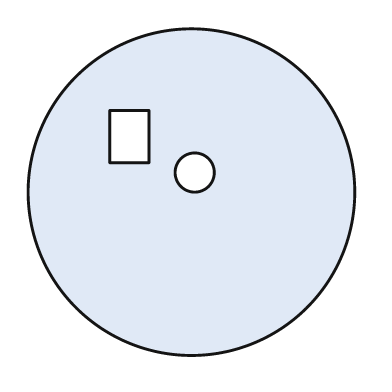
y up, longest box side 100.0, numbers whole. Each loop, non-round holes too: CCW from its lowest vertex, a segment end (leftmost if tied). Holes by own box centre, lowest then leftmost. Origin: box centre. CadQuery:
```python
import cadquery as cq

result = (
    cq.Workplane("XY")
    .moveTo(0.0, 0.0)
    .circle(50.0)
    .moveTo(1.0, 6.0)
    .circle(6.0)
    .moveTo(-25.0, 9.0)
    .lineTo(-13.0, 9.0)
    .lineTo(-13.0, 25.0)
    .lineTo(-25.0, 25.0)
    .close()
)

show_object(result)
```